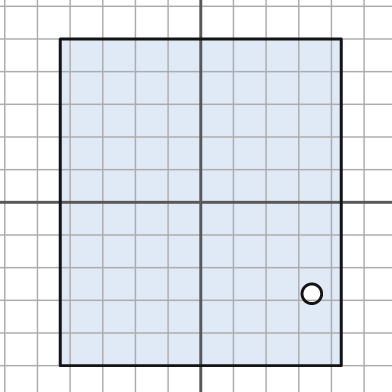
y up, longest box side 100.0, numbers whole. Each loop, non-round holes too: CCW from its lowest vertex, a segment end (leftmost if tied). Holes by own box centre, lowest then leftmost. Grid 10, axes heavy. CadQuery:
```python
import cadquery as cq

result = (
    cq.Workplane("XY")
    .moveTo(-43.0, -50.0)
    .lineTo(43.0, -50.0)
    .lineTo(43.0, 50.0)
    .lineTo(-43.0, 50.0)
    .close()
    .moveTo(34.0, -28.0)
    .circle(3.0)
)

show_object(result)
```